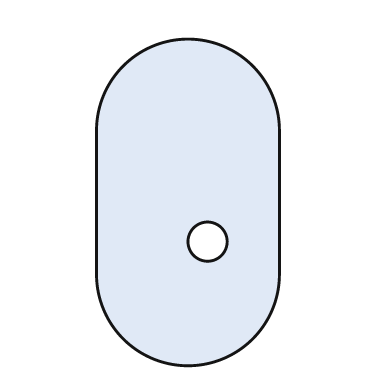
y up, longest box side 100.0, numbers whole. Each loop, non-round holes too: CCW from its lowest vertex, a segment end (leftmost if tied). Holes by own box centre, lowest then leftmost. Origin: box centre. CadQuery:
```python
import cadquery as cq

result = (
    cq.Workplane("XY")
    .moveTo(-28.0, -22.0)
    .threePointArc((0.0, -50.0), (28.0, -22.0))
    .lineTo(28.0, 22.0)
    .threePointArc((0.0, 50.0), (-28.0, 22.0))
    .close()
    .moveTo(6.0, -12.0)
    .circle(6.0)
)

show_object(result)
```